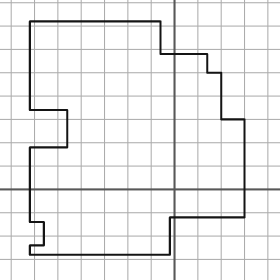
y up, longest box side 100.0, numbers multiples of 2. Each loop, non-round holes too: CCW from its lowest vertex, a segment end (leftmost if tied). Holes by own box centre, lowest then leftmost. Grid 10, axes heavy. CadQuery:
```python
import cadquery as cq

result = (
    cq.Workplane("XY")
    .moveTo(-62.0, -28.0)
    .lineTo(-2.0, -28.0)
    .lineTo(-2.0, -12.0)
    .lineTo(30.0, -12.0)
    .lineTo(30.0, 30.0)
    .lineTo(20.0, 30.0)
    .lineTo(20.0, 50.0)
    .lineTo(14.0, 50.0)
    .lineTo(14.0, 58.0)
    .lineTo(-6.0, 58.0)
    .lineTo(-6.0, 72.0)
    .lineTo(-62.0, 72.0)
    .lineTo(-62.0, 34.0)
    .lineTo(-46.0, 34.0)
    .lineTo(-46.0, 18.0)
    .lineTo(-62.0, 18.0)
    .lineTo(-62.0, -14.0)
    .lineTo(-56.0, -14.0)
    .lineTo(-56.0, -24.0)
    .lineTo(-62.0, -24.0)
    .close()
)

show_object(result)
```